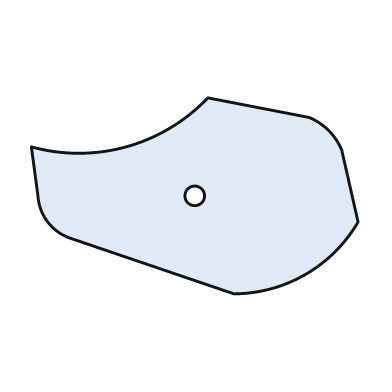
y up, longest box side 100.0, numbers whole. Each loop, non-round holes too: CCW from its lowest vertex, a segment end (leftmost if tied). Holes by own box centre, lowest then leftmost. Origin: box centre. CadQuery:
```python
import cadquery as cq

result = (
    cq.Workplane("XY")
    .moveTo(12.0, -30.0)
    .threePointArc((34.0, -24.0), (50.0, -8.0))
    .lineTo(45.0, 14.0)
    .threePointArc((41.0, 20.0), (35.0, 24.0))
    .lineTo(4.0, 30.0)
    .threePointArc((-21.0, 15.0), (-50.0, 15.0))
    .lineTo(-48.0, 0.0)
    .threePointArc((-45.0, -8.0), (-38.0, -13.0))
    .close()
    .moveTo(0.0, 0.0)
    .circle(3.0)
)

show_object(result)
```